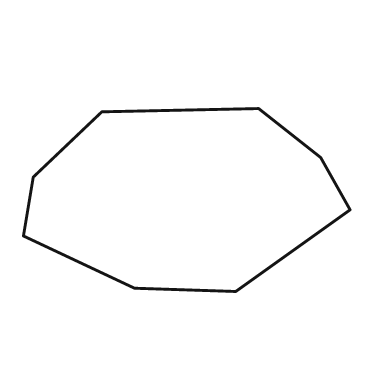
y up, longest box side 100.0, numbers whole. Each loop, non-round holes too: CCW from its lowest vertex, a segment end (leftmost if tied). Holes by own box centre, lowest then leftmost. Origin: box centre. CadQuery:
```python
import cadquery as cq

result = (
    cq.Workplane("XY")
    .moveTo(15.0, -28.0)
    .lineTo(50.0, -3.0)
    .lineTo(41.0, 13.0)
    .lineTo(22.0, 28.0)
    .lineTo(-26.0, 27.0)
    .lineTo(-47.0, 7.0)
    .lineTo(-50.0, -11.0)
    .lineTo(-16.0, -27.0)
    .close()
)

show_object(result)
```